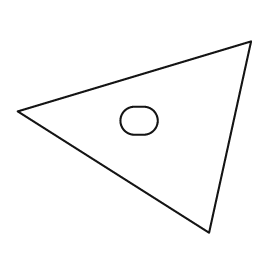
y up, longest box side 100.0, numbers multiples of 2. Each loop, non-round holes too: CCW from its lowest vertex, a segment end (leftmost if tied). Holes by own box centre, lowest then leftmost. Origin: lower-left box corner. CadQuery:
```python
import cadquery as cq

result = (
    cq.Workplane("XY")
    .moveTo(82.0, 0.0)
    .lineTo(100.0, 82.0)
    .lineTo(0.0, 52.0)
    .close()
    .moveTo(50.0, 42.0)
    .lineTo(54.0, 42.0)
    .threePointArc((60.0, 48.0), (54.0, 54.0))
    .lineTo(50.0, 54.0)
    .threePointArc((44.0, 48.0), (50.0, 42.0))
    .close()
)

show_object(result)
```